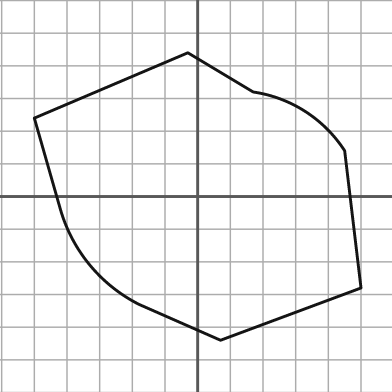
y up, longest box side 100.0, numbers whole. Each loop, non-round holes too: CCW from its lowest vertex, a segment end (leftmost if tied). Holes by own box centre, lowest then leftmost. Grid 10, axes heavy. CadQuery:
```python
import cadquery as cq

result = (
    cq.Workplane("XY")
    .moveTo(7.0, -44.0)
    .lineTo(50.0, -28.0)
    .lineTo(45.0, 14.0)
    .threePointArc((33.0, 26.0), (17.0, 32.0))
    .lineTo(-3.0, 44.0)
    .lineTo(-50.0, 24.0)
    .lineTo(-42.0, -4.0)
    .threePointArc((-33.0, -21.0), (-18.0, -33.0))
    .close()
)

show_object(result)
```